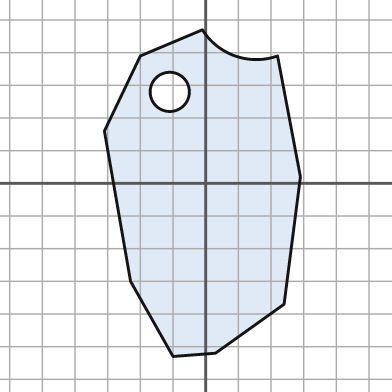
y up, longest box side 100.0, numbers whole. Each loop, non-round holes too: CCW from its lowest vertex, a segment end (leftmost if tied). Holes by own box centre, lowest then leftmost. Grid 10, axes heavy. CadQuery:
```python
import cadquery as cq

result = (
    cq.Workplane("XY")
    .moveTo(-10.0, -53.0)
    .lineTo(3.0, -52.0)
    .lineTo(24.0, -37.0)
    .lineTo(29.0, 2.0)
    .lineTo(22.0, 39.0)
    .threePointArc((9.0, 39.0), (-1.0, 47.0))
    .lineTo(-20.0, 39.0)
    .lineTo(-31.0, 16.0)
    .lineTo(-23.0, -30.0)
    .close()
    .moveTo(-11.0, 28.0)
    .circle(6.0)
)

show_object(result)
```